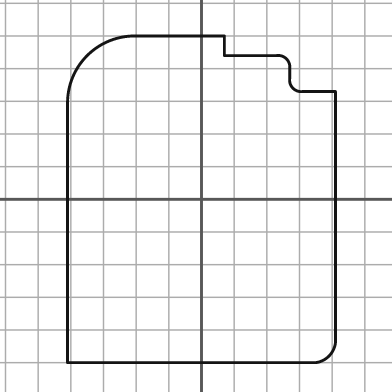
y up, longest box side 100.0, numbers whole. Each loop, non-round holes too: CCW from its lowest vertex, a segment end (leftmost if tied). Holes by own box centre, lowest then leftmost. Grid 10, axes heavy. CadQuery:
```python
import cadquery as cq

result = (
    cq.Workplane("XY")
    .moveTo(-41.0, -50.0)
    .lineTo(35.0, -50.0)
    .threePointArc((39.0, -48.0), (41.0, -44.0))
    .lineTo(41.0, 33.0)
    .lineTo(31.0, 33.0)
    .threePointArc((28.0, 34.0), (27.0, 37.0))
    .lineTo(27.0, 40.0)
    .threePointArc((26.0, 43.0), (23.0, 44.0))
    .lineTo(7.0, 44.0)
    .lineTo(7.0, 50.0)
    .lineTo(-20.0, 50.0)
    .threePointArc((-35.0, 44.0), (-41.0, 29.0))
    .close()
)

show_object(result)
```